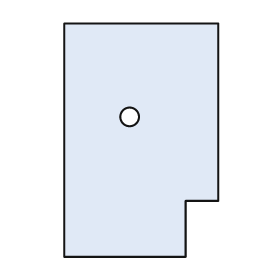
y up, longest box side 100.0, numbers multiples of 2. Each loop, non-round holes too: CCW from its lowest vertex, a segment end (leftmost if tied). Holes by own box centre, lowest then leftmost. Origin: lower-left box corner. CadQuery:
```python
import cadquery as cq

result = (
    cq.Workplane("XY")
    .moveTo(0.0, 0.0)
    .lineTo(52.0, 0.0)
    .lineTo(52.0, 24.0)
    .lineTo(66.0, 24.0)
    .lineTo(66.0, 100.0)
    .lineTo(0.0, 100.0)
    .close()
    .moveTo(28.0, 60.0)
    .circle(4.0)
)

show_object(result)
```